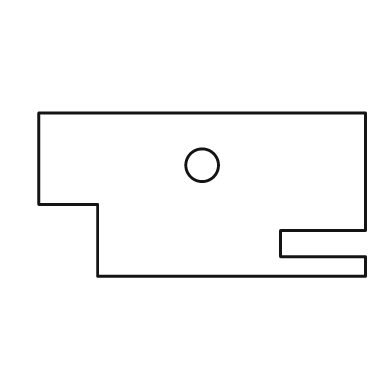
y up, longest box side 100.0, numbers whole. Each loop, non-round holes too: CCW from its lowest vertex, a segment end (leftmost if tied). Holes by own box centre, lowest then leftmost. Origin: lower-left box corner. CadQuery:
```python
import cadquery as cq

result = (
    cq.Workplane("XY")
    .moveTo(18.0, 0.0)
    .lineTo(100.0, 0.0)
    .lineTo(100.0, 6.0)
    .lineTo(74.0, 6.0)
    .lineTo(74.0, 14.0)
    .lineTo(100.0, 14.0)
    .lineTo(100.0, 50.0)
    .lineTo(0.0, 50.0)
    .lineTo(0.0, 22.0)
    .lineTo(18.0, 22.0)
    .close()
    .moveTo(50.0, 34.0)
    .circle(5.0)
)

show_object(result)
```